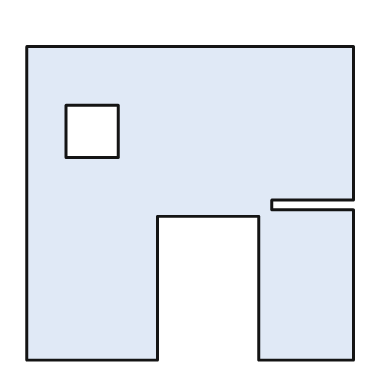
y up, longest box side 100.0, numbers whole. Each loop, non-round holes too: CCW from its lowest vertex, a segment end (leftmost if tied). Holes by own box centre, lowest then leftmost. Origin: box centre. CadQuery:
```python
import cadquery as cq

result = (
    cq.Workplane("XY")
    .moveTo(-50.0, -48.0)
    .lineTo(-10.0, -48.0)
    .lineTo(-10.0, -4.0)
    .lineTo(21.0, -4.0)
    .lineTo(21.0, -48.0)
    .lineTo(50.0, -48.0)
    .lineTo(50.0, -2.0)
    .lineTo(25.0, -2.0)
    .lineTo(25.0, 1.0)
    .lineTo(50.0, 1.0)
    .lineTo(50.0, 48.0)
    .lineTo(-50.0, 48.0)
    .close()
    .moveTo(-38.0, 14.0)
    .lineTo(-22.0, 14.0)
    .lineTo(-22.0, 30.0)
    .lineTo(-38.0, 30.0)
    .close()
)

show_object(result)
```